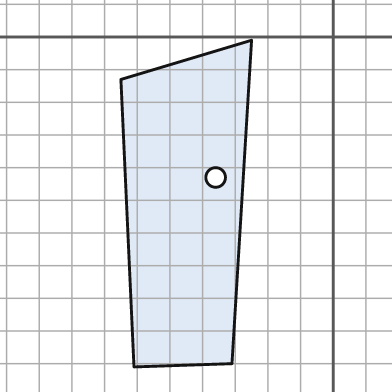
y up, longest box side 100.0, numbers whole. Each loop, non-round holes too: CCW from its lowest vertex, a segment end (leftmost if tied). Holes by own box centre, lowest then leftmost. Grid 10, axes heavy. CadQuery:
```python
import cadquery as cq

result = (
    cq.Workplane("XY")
    .moveTo(-61.0, -101.0)
    .lineTo(-31.0, -100.0)
    .lineTo(-25.0, -1.0)
    .lineTo(-65.0, -13.0)
    .close()
    .moveTo(-36.0, -43.0)
    .circle(3.0)
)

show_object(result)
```